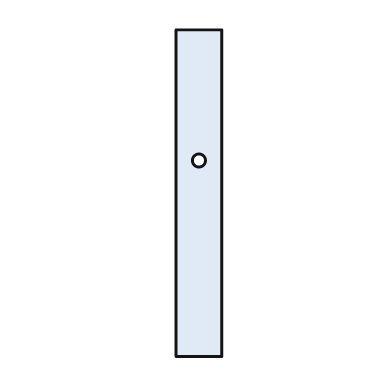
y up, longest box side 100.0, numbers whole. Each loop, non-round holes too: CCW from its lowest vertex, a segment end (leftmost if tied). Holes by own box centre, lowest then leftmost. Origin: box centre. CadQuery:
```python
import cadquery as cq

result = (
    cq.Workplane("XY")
    .moveTo(-7.0, -50.0)
    .lineTo(7.0, -50.0)
    .lineTo(7.0, 50.0)
    .lineTo(-7.0, 50.0)
    .close()
    .moveTo(0.0, 10.0)
    .circle(2.0)
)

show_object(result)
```